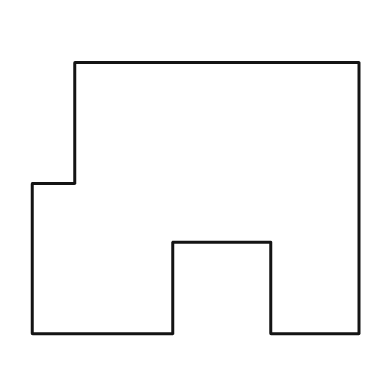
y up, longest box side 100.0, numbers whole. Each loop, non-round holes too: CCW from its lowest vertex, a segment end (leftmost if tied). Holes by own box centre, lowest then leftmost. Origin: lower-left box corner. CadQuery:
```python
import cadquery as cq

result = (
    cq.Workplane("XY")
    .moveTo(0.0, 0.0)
    .lineTo(43.0, 0.0)
    .lineTo(43.0, 28.0)
    .lineTo(73.0, 28.0)
    .lineTo(73.0, 0.0)
    .lineTo(100.0, 0.0)
    .lineTo(100.0, 83.0)
    .lineTo(13.0, 83.0)
    .lineTo(13.0, 46.0)
    .lineTo(0.0, 46.0)
    .close()
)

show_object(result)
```